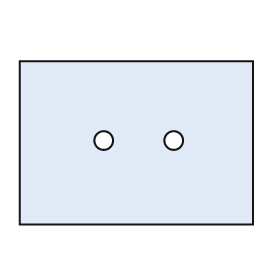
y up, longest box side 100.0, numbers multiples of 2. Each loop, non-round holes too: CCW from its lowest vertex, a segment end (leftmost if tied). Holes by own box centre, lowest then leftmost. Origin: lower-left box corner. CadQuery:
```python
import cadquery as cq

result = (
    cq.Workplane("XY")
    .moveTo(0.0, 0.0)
    .lineTo(100.0, 0.0)
    .lineTo(100.0, 70.0)
    .lineTo(0.0, 70.0)
    .close()
    .moveTo(36.0, 36.0)
    .circle(4.0)
    .moveTo(66.0, 36.0)
    .circle(4.0)
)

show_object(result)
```